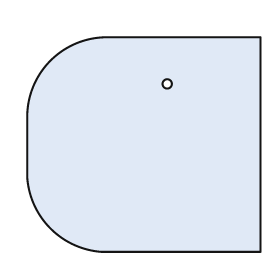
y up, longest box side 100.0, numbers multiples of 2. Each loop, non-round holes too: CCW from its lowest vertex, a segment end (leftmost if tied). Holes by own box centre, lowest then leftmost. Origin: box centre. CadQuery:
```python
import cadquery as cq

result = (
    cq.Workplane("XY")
    .moveTo(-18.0, -46.0)
    .lineTo(50.0, -46.0)
    .lineTo(50.0, 46.0)
    .lineTo(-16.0, 46.0)
    .threePointArc((-40.0, 36.0), (-50.0, 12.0))
    .lineTo(-50.0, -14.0)
    .threePointArc((-40.0, -36.0), (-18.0, -46.0))
    .close()
    .moveTo(10.0, 26.0)
    .circle(2.0)
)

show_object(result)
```